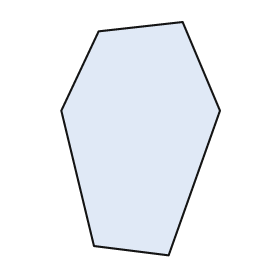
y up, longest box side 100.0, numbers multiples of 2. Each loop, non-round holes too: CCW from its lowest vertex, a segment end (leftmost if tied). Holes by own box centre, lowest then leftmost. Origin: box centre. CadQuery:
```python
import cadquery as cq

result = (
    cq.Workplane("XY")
    .moveTo(12.0, -50.0)
    .lineTo(34.0, 12.0)
    .lineTo(18.0, 50.0)
    .lineTo(-18.0, 46.0)
    .lineTo(-34.0, 12.0)
    .lineTo(-20.0, -46.0)
    .close()
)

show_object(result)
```